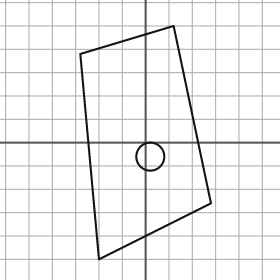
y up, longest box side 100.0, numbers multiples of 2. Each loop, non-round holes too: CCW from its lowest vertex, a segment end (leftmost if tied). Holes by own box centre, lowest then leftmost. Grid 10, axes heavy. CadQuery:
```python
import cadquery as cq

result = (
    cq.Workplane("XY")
    .moveTo(-20.0, -50.0)
    .lineTo(28.0, -26.0)
    .lineTo(12.0, 50.0)
    .lineTo(-28.0, 38.0)
    .close()
    .moveTo(2.0, -6.0)
    .circle(6.0)
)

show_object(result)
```